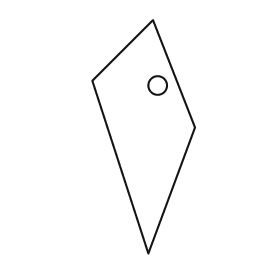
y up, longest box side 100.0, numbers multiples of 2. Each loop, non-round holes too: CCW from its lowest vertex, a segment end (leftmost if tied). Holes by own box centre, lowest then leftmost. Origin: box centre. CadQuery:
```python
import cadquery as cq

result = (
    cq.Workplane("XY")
    .moveTo(2.0, -50.0)
    .lineTo(22.0, 4.0)
    .lineTo(4.0, 50.0)
    .lineTo(-22.0, 24.0)
    .close()
    .moveTo(6.0, 22.0)
    .circle(4.0)
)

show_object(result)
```